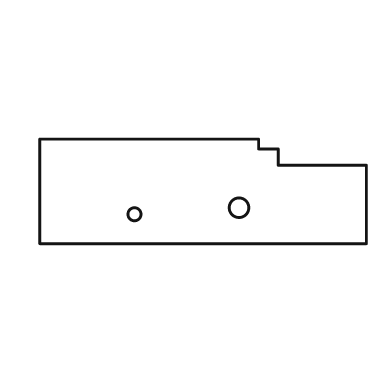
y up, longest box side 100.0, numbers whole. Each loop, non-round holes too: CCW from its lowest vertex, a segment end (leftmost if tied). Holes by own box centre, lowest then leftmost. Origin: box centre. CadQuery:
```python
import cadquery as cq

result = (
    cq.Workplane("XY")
    .moveTo(-50.0, -16.0)
    .lineTo(50.0, -16.0)
    .lineTo(50.0, 8.0)
    .lineTo(23.0, 8.0)
    .lineTo(23.0, 13.0)
    .lineTo(17.0, 13.0)
    .lineTo(17.0, 16.0)
    .lineTo(-50.0, 16.0)
    .close()
    .moveTo(-21.0, -7.0)
    .circle(2.0)
    .moveTo(11.0, -5.0)
    .circle(3.0)
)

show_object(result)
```